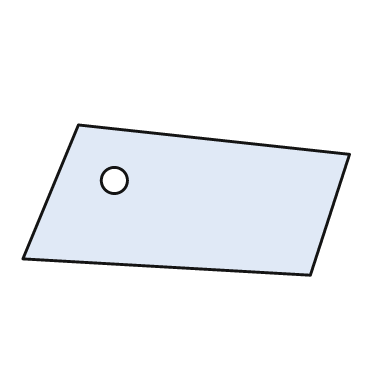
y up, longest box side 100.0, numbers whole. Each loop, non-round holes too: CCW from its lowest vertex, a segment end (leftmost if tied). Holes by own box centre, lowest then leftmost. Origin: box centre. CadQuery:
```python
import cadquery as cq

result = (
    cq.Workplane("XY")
    .moveTo(38.0, -23.0)
    .lineTo(50.0, 14.0)
    .lineTo(-33.0, 23.0)
    .lineTo(-50.0, -18.0)
    .close()
    .moveTo(-22.0, 6.0)
    .circle(4.0)
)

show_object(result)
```